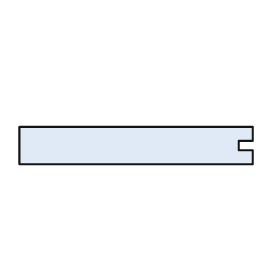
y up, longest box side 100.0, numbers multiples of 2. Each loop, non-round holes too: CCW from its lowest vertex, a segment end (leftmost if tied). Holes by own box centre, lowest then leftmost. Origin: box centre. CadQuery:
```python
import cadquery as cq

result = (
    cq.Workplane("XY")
    .moveTo(-50.0, -8.0)
    .lineTo(50.0, -8.0)
    .lineTo(50.0, -2.0)
    .lineTo(44.0, -2.0)
    .lineTo(44.0, 2.0)
    .lineTo(50.0, 2.0)
    .lineTo(50.0, 8.0)
    .lineTo(-50.0, 8.0)
    .close()
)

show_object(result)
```